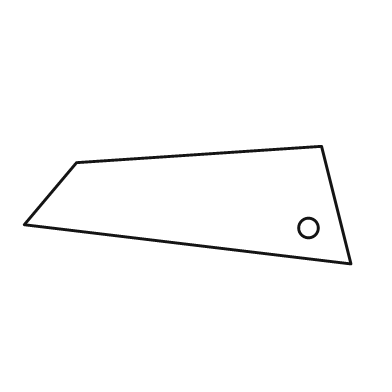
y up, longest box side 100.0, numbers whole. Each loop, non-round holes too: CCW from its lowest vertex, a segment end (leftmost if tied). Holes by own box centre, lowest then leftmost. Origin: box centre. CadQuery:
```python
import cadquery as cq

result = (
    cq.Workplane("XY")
    .moveTo(50.0, -18.0)
    .lineTo(41.0, 18.0)
    .lineTo(-34.0, 13.0)
    .lineTo(-50.0, -6.0)
    .close()
    .moveTo(37.0, -7.0)
    .circle(3.0)
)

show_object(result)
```